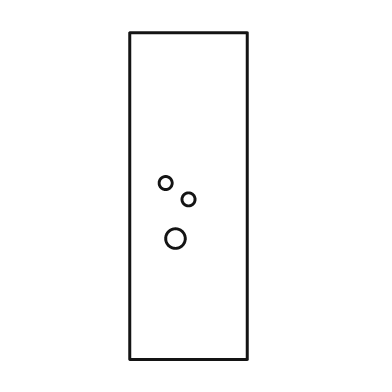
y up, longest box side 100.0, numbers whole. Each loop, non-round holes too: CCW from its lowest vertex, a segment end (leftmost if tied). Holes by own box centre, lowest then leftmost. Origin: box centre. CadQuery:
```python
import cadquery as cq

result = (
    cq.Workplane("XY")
    .moveTo(-18.0, -50.0)
    .lineTo(18.0, -50.0)
    .lineTo(18.0, 50.0)
    .lineTo(-18.0, 50.0)
    .close()
    .moveTo(-4.0, -13.0)
    .circle(3.0)
    .moveTo(0.0, -1.0)
    .circle(2.0)
    .moveTo(-7.0, 4.0)
    .circle(2.0)
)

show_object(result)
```